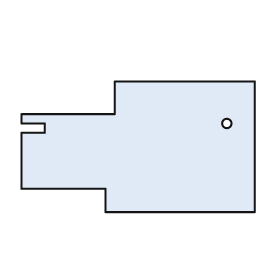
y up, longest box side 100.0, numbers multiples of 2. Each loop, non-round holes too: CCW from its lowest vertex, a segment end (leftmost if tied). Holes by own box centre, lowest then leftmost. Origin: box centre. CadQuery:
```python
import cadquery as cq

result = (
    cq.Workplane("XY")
    .moveTo(-14.0, -28.0)
    .lineTo(50.0, -28.0)
    .lineTo(50.0, 28.0)
    .lineTo(-10.0, 28.0)
    .lineTo(-10.0, 14.0)
    .lineTo(-50.0, 14.0)
    .lineTo(-50.0, 10.0)
    .lineTo(-40.0, 10.0)
    .lineTo(-40.0, 6.0)
    .lineTo(-50.0, 6.0)
    .lineTo(-50.0, -18.0)
    .lineTo(-14.0, -18.0)
    .close()
    .moveTo(38.0, 10.0)
    .circle(2.0)
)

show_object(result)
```